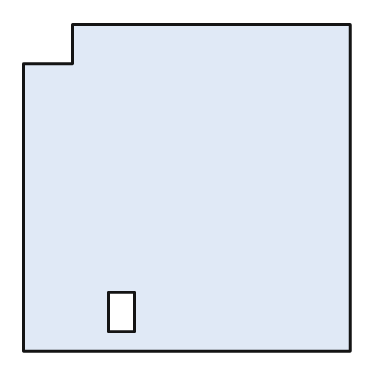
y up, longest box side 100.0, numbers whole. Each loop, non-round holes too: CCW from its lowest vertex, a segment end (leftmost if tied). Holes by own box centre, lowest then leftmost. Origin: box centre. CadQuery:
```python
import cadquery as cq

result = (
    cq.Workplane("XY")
    .moveTo(-50.0, -50.0)
    .lineTo(50.0, -50.0)
    .lineTo(50.0, 50.0)
    .lineTo(-35.0, 50.0)
    .lineTo(-35.0, 38.0)
    .lineTo(-50.0, 38.0)
    .close()
    .moveTo(-24.0, -44.0)
    .lineTo(-16.0, -44.0)
    .lineTo(-16.0, -32.0)
    .lineTo(-24.0, -32.0)
    .close()
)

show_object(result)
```